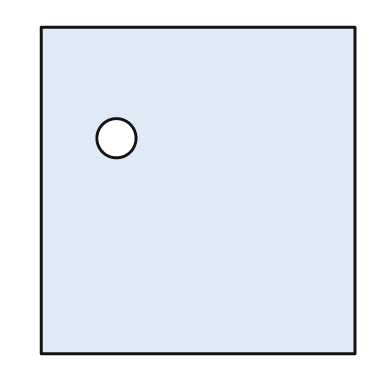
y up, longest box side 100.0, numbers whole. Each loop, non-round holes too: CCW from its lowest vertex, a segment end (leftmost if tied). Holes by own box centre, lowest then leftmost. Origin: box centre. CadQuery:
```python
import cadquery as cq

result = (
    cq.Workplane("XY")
    .moveTo(-48.0, -50.0)
    .lineTo(48.0, -50.0)
    .lineTo(48.0, 50.0)
    .lineTo(-48.0, 50.0)
    .close()
    .moveTo(-25.0, 16.0)
    .circle(6.0)
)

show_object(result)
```